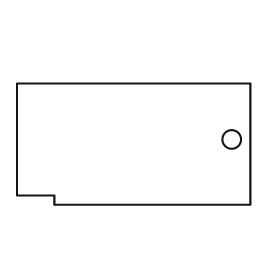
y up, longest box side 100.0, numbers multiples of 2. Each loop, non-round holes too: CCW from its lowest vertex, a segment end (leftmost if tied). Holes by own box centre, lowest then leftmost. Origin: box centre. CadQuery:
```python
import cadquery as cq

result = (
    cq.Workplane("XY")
    .moveTo(-34.0, -26.0)
    .lineTo(50.0, -26.0)
    .lineTo(50.0, 26.0)
    .lineTo(-50.0, 26.0)
    .lineTo(-50.0, -22.0)
    .lineTo(-34.0, -22.0)
    .close()
    .moveTo(42.0, 2.0)
    .circle(4.0)
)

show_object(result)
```